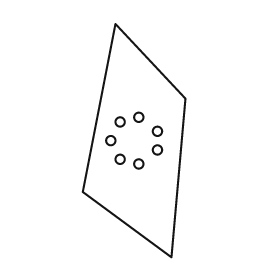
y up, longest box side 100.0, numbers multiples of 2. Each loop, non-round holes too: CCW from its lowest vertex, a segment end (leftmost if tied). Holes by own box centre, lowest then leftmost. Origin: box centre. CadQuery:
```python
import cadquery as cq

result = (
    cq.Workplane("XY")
    .moveTo(16.0, -50.0)
    .lineTo(22.0, 18.0)
    .lineTo(-8.0, 50.0)
    .lineTo(-22.0, -22.0)
    .close()
    .moveTo(2.0, -10.0)
    .circle(2.0)
    .moveTo(-6.0, -8.0)
    .circle(2.0)
    .moveTo(10.0, -4.0)
    .circle(2.0)
    .moveTo(-10.0, 0.0)
    .circle(2.0)
    .moveTo(10.0, 4.0)
    .circle(2.0)
    .moveTo(-6.0, 8.0)
    .circle(2.0)
    .moveTo(2.0, 10.0)
    .circle(2.0)
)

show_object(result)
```